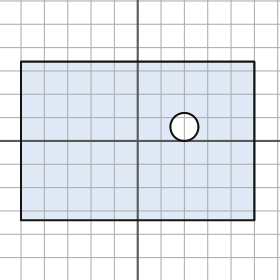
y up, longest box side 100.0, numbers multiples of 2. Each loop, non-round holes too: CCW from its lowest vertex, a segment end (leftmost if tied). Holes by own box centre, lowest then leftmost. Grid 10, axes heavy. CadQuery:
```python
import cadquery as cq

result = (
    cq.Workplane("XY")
    .moveTo(-50.0, -34.0)
    .lineTo(50.0, -34.0)
    .lineTo(50.0, 34.0)
    .lineTo(-50.0, 34.0)
    .close()
    .moveTo(20.0, 6.0)
    .circle(6.0)
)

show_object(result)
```